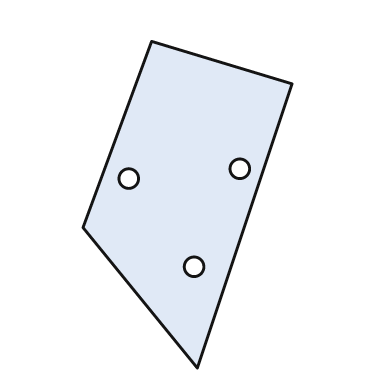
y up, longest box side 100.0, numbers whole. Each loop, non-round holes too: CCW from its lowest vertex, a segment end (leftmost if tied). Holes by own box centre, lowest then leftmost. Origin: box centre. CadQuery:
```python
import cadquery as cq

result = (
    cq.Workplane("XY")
    .moveTo(3.0, -50.0)
    .lineTo(32.0, 37.0)
    .lineTo(-11.0, 50.0)
    .lineTo(-32.0, -7.0)
    .close()
    .moveTo(2.0, -19.0)
    .circle(3.0)
    .moveTo(-18.0, 8.0)
    .circle(3.0)
    .moveTo(16.0, 11.0)
    .circle(3.0)
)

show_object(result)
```